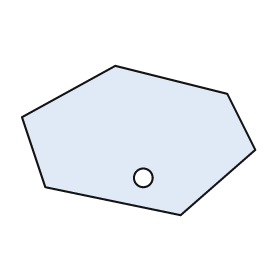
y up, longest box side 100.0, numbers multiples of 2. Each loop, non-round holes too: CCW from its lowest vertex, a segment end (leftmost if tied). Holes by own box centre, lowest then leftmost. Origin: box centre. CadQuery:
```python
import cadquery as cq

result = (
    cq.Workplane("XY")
    .moveTo(18.0, -32.0)
    .lineTo(50.0, -4.0)
    .lineTo(38.0, 20.0)
    .lineTo(-10.0, 32.0)
    .lineTo(-50.0, 10.0)
    .lineTo(-40.0, -20.0)
    .close()
    .moveTo(2.0, -16.0)
    .circle(4.0)
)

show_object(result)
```